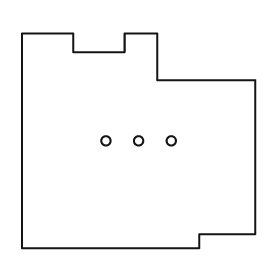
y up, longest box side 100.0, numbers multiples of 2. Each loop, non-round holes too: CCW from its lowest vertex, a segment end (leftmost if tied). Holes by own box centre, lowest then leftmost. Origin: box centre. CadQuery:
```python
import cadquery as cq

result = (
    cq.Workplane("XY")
    .moveTo(-50.0, -46.0)
    .lineTo(26.0, -46.0)
    .lineTo(26.0, -40.0)
    .lineTo(50.0, -40.0)
    .lineTo(50.0, 26.0)
    .lineTo(8.0, 26.0)
    .lineTo(8.0, 46.0)
    .lineTo(-6.0, 46.0)
    .lineTo(-6.0, 38.0)
    .lineTo(-28.0, 38.0)
    .lineTo(-28.0, 46.0)
    .lineTo(-50.0, 46.0)
    .close()
    .moveTo(-14.0, 0.0)
    .circle(2.0)
    .moveTo(0.0, 0.0)
    .circle(2.0)
    .moveTo(14.0, 0.0)
    .circle(2.0)
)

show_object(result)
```